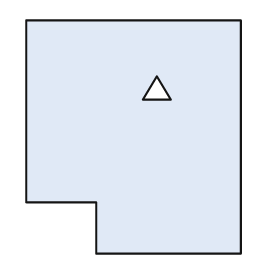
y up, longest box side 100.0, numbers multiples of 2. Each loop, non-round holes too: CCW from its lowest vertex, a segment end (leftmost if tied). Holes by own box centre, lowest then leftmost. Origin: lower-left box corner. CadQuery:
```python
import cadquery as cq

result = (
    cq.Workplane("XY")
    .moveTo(30.0, 0.0)
    .lineTo(92.0, 0.0)
    .lineTo(92.0, 100.0)
    .lineTo(0.0, 100.0)
    .lineTo(0.0, 22.0)
    .lineTo(30.0, 22.0)
    .close()
    .moveTo(50.0, 66.0)
    .lineTo(62.0, 66.0)
    .lineTo(56.0, 76.0)
    .close()
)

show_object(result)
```